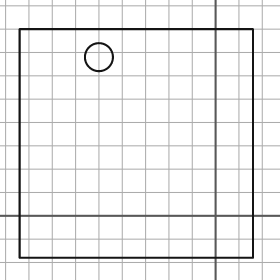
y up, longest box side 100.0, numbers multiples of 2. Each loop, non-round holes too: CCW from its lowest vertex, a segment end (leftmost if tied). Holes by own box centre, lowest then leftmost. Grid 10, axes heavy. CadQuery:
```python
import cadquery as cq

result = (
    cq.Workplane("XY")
    .moveTo(-84.0, -18.0)
    .lineTo(16.0, -18.0)
    .lineTo(16.0, 80.0)
    .lineTo(-84.0, 80.0)
    .close()
    .moveTo(-50.0, 68.0)
    .circle(6.0)
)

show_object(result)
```